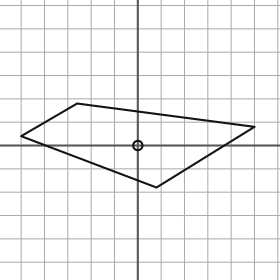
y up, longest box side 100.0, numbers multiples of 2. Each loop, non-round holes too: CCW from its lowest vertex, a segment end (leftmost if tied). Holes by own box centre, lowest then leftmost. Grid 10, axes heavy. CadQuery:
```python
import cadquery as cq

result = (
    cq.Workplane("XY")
    .moveTo(8.0, -18.0)
    .lineTo(50.0, 8.0)
    .lineTo(-26.0, 18.0)
    .lineTo(-50.0, 4.0)
    .close()
    .moveTo(0.0, 0.0)
    .circle(2.0)
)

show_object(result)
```